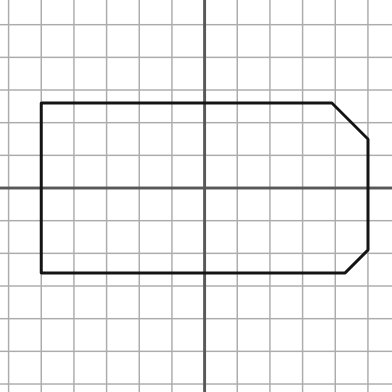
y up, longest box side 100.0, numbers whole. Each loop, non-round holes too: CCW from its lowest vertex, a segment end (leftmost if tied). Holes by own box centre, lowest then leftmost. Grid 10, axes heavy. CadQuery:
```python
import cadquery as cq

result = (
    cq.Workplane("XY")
    .moveTo(-50.0, -26.0)
    .lineTo(43.0, -26.0)
    .lineTo(50.0, -19.0)
    .lineTo(50.0, 15.0)
    .lineTo(39.0, 26.0)
    .lineTo(-50.0, 26.0)
    .close()
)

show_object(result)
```